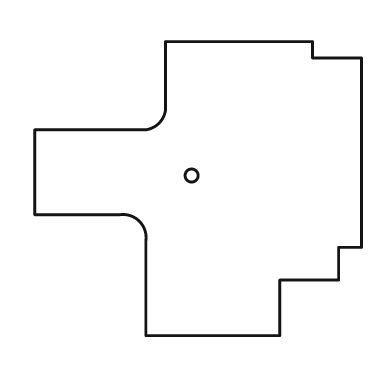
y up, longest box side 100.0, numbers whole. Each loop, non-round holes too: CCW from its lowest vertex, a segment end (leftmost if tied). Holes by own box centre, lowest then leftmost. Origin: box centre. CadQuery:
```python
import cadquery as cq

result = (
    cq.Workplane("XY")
    .moveTo(-16.0, -45.0)
    .lineTo(25.0, -45.0)
    .lineTo(25.0, -28.0)
    .lineTo(43.0, -28.0)
    .lineTo(43.0, -18.0)
    .lineTo(50.0, -18.0)
    .lineTo(50.0, 40.0)
    .lineTo(35.0, 40.0)
    .lineTo(35.0, 45.0)
    .lineTo(-10.0, 45.0)
    .lineTo(-10.0, 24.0)
    .threePointArc((-12.0, 20.0), (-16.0, 18.0))
    .lineTo(-50.0, 18.0)
    .lineTo(-50.0, -8.0)
    .lineTo(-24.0, -8.0)
    .threePointArc((-18.0, -10.0), (-16.0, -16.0))
    .close()
    .moveTo(-2.0, 4.0)
    .circle(2.0)
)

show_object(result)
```